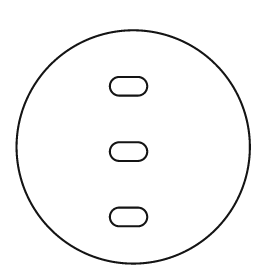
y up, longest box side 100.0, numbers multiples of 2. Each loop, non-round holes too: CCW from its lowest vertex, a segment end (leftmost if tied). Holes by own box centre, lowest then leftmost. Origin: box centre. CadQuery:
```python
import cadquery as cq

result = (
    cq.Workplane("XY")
    .moveTo(0.0, 0.0)
    .circle(50.0)
    .moveTo(-6.0, -34.0)
    .lineTo(2.0, -34.0)
    .threePointArc((6.0, -30.0), (2.0, -26.0))
    .lineTo(-6.0, -26.0)
    .threePointArc((-10.0, -30.0), (-6.0, -34.0))
    .close()
    .moveTo(-6.0, -6.0)
    .lineTo(2.0, -6.0)
    .threePointArc((6.0, -2.0), (2.0, 2.0))
    .lineTo(-6.0, 2.0)
    .threePointArc((-10.0, -2.0), (-6.0, -6.0))
    .close()
    .moveTo(-6.0, 22.0)
    .lineTo(2.0, 22.0)
    .threePointArc((6.0, 26.0), (2.0, 30.0))
    .lineTo(-6.0, 30.0)
    .threePointArc((-10.0, 26.0), (-6.0, 22.0))
    .close()
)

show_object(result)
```